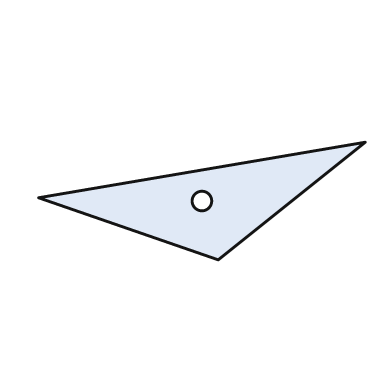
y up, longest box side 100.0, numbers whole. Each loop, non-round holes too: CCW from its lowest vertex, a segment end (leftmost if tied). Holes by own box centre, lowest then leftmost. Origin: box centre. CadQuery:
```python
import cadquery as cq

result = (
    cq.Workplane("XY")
    .moveTo(5.0, -18.0)
    .lineTo(50.0, 18.0)
    .lineTo(-50.0, 1.0)
    .close()
    .moveTo(0.0, 0.0)
    .circle(3.0)
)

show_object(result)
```